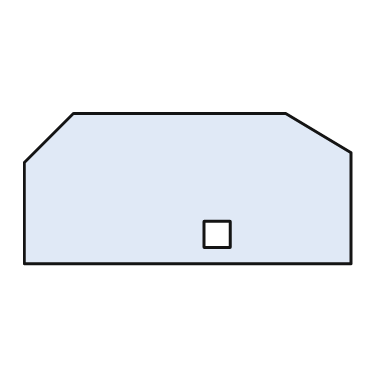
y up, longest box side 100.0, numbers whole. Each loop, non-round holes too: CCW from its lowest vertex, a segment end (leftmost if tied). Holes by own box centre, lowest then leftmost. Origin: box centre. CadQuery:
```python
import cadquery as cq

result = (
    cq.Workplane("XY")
    .moveTo(-50.0, -23.0)
    .lineTo(50.0, -23.0)
    .lineTo(50.0, 11.0)
    .lineTo(30.0, 23.0)
    .lineTo(-35.0, 23.0)
    .lineTo(-50.0, 8.0)
    .close()
    .moveTo(5.0, -18.0)
    .lineTo(13.0, -18.0)
    .lineTo(13.0, -10.0)
    .lineTo(5.0, -10.0)
    .close()
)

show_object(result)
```